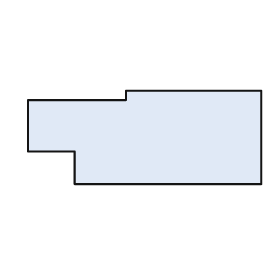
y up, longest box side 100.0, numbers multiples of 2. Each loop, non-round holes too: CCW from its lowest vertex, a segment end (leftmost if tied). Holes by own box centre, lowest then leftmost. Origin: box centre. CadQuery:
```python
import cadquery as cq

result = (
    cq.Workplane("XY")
    .moveTo(-30.0, -20.0)
    .lineTo(50.0, -20.0)
    .lineTo(50.0, 20.0)
    .lineTo(-8.0, 20.0)
    .lineTo(-8.0, 16.0)
    .lineTo(-50.0, 16.0)
    .lineTo(-50.0, -6.0)
    .lineTo(-30.0, -6.0)
    .close()
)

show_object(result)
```